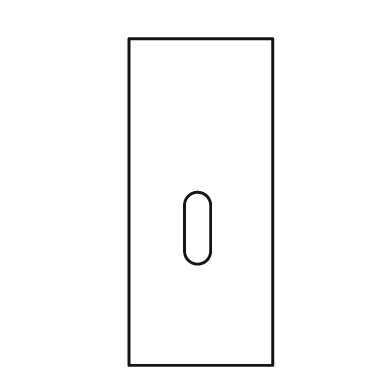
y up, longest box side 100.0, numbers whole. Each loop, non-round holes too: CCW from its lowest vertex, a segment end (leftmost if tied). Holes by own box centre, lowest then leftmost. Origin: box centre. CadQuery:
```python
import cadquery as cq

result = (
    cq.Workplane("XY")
    .moveTo(-22.0, -50.0)
    .lineTo(22.0, -50.0)
    .lineTo(22.0, 50.0)
    .lineTo(-22.0, 50.0)
    .close()
    .moveTo(-5.0, -15.0)
    .threePointArc((-1.0, -19.0), (3.0, -15.0))
    .lineTo(3.0, -1.0)
    .threePointArc((-1.0, 3.0), (-5.0, -1.0))
    .close()
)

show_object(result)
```